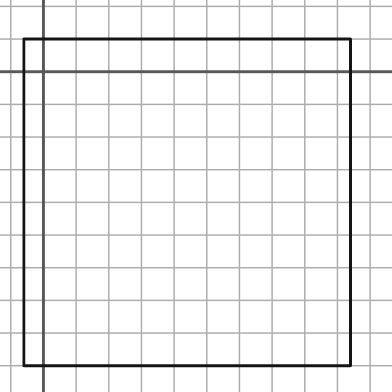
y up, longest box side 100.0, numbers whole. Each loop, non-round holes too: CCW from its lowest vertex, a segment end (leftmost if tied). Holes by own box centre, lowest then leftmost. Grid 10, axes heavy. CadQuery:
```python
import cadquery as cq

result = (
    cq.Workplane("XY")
    .moveTo(-6.0, -90.0)
    .lineTo(94.0, -90.0)
    .lineTo(94.0, 10.0)
    .lineTo(-6.0, 10.0)
    .close()
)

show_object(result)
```